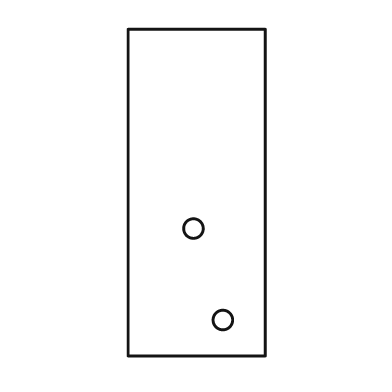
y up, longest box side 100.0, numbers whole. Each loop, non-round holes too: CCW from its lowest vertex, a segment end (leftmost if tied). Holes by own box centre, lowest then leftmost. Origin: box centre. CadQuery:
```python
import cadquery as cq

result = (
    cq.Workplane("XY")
    .moveTo(-21.0, -50.0)
    .lineTo(21.0, -50.0)
    .lineTo(21.0, 50.0)
    .lineTo(-21.0, 50.0)
    .close()
    .moveTo(8.0, -39.0)
    .circle(3.0)
    .moveTo(-1.0, -11.0)
    .circle(3.0)
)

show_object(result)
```